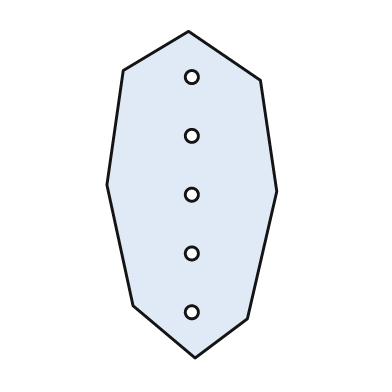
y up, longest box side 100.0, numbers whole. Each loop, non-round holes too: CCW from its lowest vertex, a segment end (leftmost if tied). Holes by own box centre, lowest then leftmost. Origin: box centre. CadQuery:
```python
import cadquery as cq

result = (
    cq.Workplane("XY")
    .moveTo(1.0, -50.0)
    .lineTo(17.0, -38.0)
    .lineTo(26.0, 1.0)
    .lineTo(21.0, 35.0)
    .lineTo(-1.0, 50.0)
    .lineTo(-21.0, 38.0)
    .lineTo(-26.0, 3.0)
    .lineTo(-18.0, -34.0)
    .close()
    .moveTo(0.0, -36.0)
    .circle(2.0)
    .moveTo(0.0, -18.0)
    .circle(2.0)
    .moveTo(0.0, 0.0)
    .circle(2.0)
    .moveTo(0.0, 18.0)
    .circle(2.0)
    .moveTo(0.0, 36.0)
    .circle(2.0)
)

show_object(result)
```